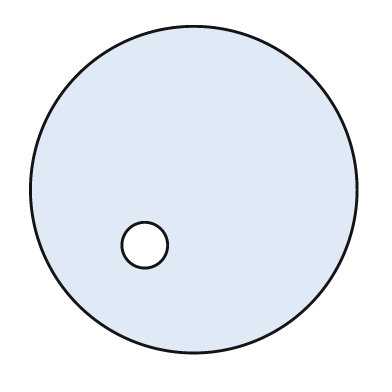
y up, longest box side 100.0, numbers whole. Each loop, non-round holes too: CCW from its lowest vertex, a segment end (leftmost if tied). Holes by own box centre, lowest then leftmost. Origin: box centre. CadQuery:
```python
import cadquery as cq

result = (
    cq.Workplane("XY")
    .moveTo(0.0, 0.0)
    .circle(50.0)
    .moveTo(-15.0, -17.0)
    .circle(7.0)
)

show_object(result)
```